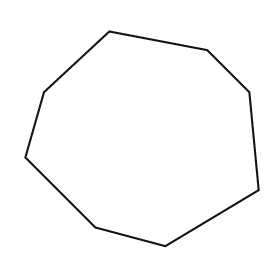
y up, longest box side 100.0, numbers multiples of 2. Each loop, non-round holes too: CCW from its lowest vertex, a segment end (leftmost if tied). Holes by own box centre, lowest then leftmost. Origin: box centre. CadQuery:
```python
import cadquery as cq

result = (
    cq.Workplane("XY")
    .moveTo(10.0, -46.0)
    .lineTo(50.0, -22.0)
    .lineTo(46.0, 20.0)
    .lineTo(28.0, 38.0)
    .lineTo(-14.0, 46.0)
    .lineTo(-42.0, 20.0)
    .lineTo(-50.0, -8.0)
    .lineTo(-20.0, -38.0)
    .close()
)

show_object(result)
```